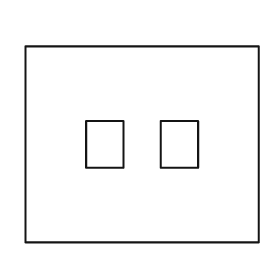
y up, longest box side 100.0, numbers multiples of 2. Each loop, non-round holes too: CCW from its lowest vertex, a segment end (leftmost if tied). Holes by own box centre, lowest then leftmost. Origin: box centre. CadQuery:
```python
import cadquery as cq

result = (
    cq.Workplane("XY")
    .moveTo(-50.0, -42.0)
    .lineTo(50.0, -42.0)
    .lineTo(50.0, 42.0)
    .lineTo(-50.0, 42.0)
    .close()
    .moveTo(-24.0, -10.0)
    .lineTo(-8.0, -10.0)
    .lineTo(-8.0, 10.0)
    .lineTo(-24.0, 10.0)
    .close()
    .moveTo(8.0, -10.0)
    .lineTo(24.0, -10.0)
    .lineTo(24.0, 10.0)
    .lineTo(8.0, 10.0)
    .close()
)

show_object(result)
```